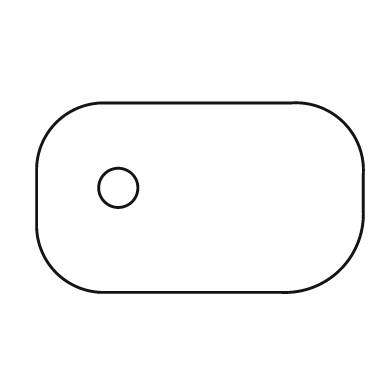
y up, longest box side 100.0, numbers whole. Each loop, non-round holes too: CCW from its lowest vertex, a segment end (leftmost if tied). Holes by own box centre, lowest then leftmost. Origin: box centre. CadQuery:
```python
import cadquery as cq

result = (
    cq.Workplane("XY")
    .moveTo(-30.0, -29.0)
    .lineTo(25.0, -29.0)
    .threePointArc((43.0, -22.0), (50.0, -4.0))
    .lineTo(50.0, 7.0)
    .threePointArc((44.0, 23.0), (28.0, 29.0))
    .lineTo(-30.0, 29.0)
    .threePointArc((-44.0, 23.0), (-50.0, 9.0))
    .lineTo(-50.0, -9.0)
    .threePointArc((-44.0, -23.0), (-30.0, -29.0))
    .close()
    .moveTo(-25.0, 3.0)
    .circle(6.0)
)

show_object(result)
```